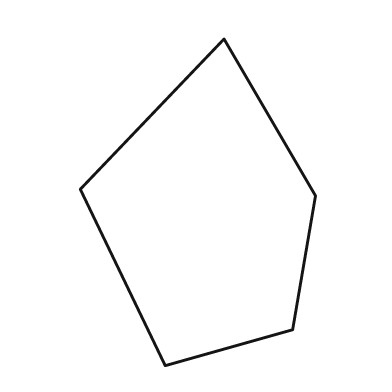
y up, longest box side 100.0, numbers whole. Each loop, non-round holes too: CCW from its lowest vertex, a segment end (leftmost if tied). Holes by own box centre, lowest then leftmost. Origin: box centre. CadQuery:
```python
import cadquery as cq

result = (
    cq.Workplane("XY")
    .moveTo(-10.0, -50.0)
    .lineTo(29.0, -39.0)
    .lineTo(36.0, 2.0)
    .lineTo(8.0, 50.0)
    .lineTo(-36.0, 4.0)
    .close()
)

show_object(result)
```